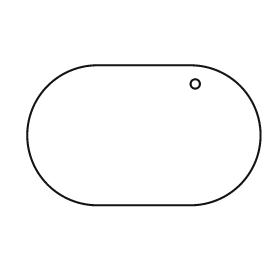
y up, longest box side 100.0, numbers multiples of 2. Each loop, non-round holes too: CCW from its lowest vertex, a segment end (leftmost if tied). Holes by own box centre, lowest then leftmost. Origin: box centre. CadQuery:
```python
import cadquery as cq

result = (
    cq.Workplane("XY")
    .moveTo(-20.0, -30.0)
    .lineTo(20.0, -30.0)
    .threePointArc((50.0, 0.0), (20.0, 30.0))
    .lineTo(-20.0, 30.0)
    .threePointArc((-50.0, 0.0), (-20.0, -30.0))
    .close()
    .moveTo(22.0, 22.0)
    .circle(2.0)
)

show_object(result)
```